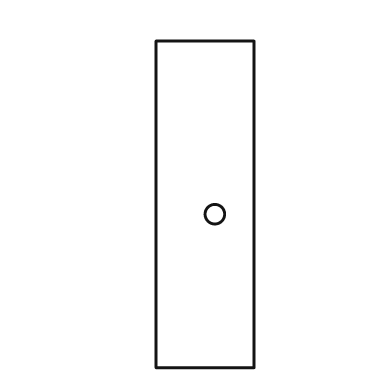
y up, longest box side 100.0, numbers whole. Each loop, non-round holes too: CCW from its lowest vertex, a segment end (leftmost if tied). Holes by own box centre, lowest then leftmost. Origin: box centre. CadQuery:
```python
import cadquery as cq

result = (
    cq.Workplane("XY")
    .moveTo(-15.0, -50.0)
    .lineTo(15.0, -50.0)
    .lineTo(15.0, 50.0)
    .lineTo(-15.0, 50.0)
    .close()
    .moveTo(3.0, -3.0)
    .circle(3.0)
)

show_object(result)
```